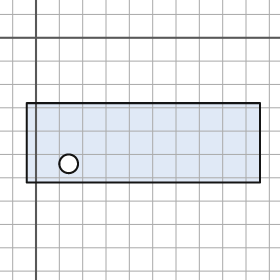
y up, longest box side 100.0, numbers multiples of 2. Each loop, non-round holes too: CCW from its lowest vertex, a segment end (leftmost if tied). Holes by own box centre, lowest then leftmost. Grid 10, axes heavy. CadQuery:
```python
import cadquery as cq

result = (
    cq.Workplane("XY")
    .moveTo(-4.0, -62.0)
    .lineTo(96.0, -62.0)
    .lineTo(96.0, -28.0)
    .lineTo(-4.0, -28.0)
    .close()
    .moveTo(14.0, -54.0)
    .circle(4.0)
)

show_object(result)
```